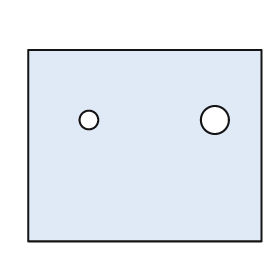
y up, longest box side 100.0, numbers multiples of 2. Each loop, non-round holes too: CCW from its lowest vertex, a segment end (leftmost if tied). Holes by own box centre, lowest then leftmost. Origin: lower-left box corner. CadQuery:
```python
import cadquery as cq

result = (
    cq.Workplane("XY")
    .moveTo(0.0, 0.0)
    .lineTo(100.0, 0.0)
    .lineTo(100.0, 82.0)
    .lineTo(0.0, 82.0)
    .close()
    .moveTo(26.0, 52.0)
    .circle(4.0)
    .moveTo(80.0, 52.0)
    .circle(6.0)
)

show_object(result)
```